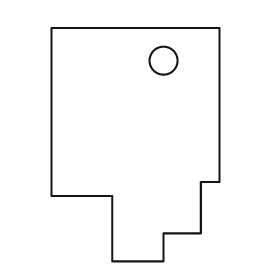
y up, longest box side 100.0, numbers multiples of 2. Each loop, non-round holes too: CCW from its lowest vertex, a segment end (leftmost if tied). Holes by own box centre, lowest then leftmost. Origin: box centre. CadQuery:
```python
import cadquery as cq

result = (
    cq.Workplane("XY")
    .moveTo(-10.0, -50.0)
    .lineTo(12.0, -50.0)
    .lineTo(12.0, -38.0)
    .lineTo(28.0, -38.0)
    .lineTo(28.0, -16.0)
    .lineTo(36.0, -16.0)
    .lineTo(36.0, 50.0)
    .lineTo(-36.0, 50.0)
    .lineTo(-36.0, -22.0)
    .lineTo(-10.0, -22.0)
    .close()
    .moveTo(12.0, 36.0)
    .circle(6.0)
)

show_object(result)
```